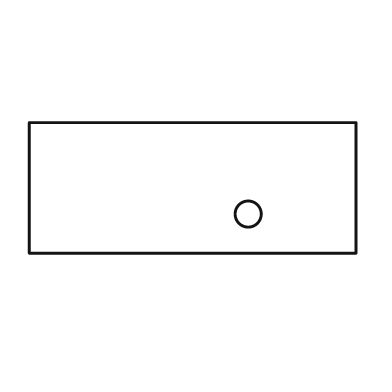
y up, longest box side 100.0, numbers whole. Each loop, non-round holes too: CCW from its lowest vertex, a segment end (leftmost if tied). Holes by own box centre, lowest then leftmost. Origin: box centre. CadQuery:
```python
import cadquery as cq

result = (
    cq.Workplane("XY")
    .moveTo(-50.0, -20.0)
    .lineTo(50.0, -20.0)
    .lineTo(50.0, 20.0)
    .lineTo(-50.0, 20.0)
    .close()
    .moveTo(17.0, -8.0)
    .circle(4.0)
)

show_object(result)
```